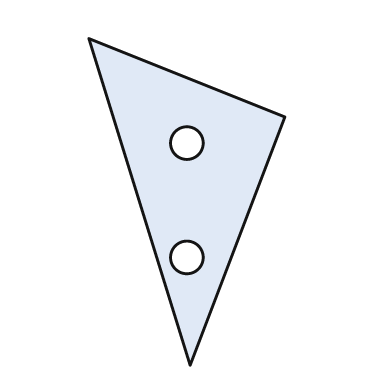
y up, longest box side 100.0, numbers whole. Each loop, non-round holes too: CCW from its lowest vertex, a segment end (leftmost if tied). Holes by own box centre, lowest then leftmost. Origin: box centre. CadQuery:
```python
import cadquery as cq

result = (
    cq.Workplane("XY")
    .moveTo(1.0, -50.0)
    .lineTo(30.0, 26.0)
    .lineTo(-30.0, 50.0)
    .close()
    .moveTo(0.0, -17.0)
    .circle(5.0)
    .moveTo(0.0, 18.0)
    .circle(5.0)
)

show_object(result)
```